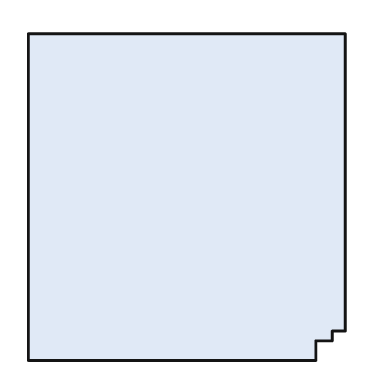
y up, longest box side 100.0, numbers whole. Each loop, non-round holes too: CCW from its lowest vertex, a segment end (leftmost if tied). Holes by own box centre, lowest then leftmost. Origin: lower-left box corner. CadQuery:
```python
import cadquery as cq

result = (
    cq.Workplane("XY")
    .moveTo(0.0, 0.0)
    .lineTo(88.0, 0.0)
    .lineTo(88.0, 6.0)
    .lineTo(93.0, 6.0)
    .lineTo(93.0, 9.0)
    .lineTo(97.0, 9.0)
    .lineTo(97.0, 100.0)
    .lineTo(0.0, 100.0)
    .close()
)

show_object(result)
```